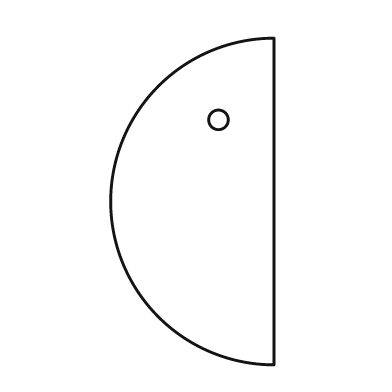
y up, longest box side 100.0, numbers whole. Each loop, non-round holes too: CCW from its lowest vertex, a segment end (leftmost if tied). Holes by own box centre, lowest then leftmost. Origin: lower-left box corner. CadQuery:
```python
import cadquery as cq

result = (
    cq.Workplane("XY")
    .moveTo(50.0, 0.0)
    .lineTo(50.0, 100.0)
    .threePointArc((0.0, 50.0), (50.0, 0.0))
    .close()
    .moveTo(33.0, 75.0)
    .circle(3.0)
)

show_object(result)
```